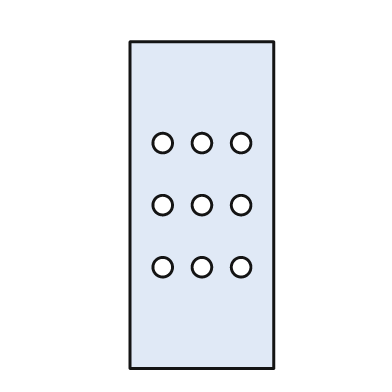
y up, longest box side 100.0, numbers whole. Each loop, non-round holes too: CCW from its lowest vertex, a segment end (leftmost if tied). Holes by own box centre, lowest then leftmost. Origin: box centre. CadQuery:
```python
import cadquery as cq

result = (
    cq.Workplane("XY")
    .moveTo(-22.0, -50.0)
    .lineTo(22.0, -50.0)
    .lineTo(22.0, 50.0)
    .lineTo(-22.0, 50.0)
    .close()
    .moveTo(-12.0, -19.0)
    .circle(3.0)
    .moveTo(0.0, -19.0)
    .circle(3.0)
    .moveTo(12.0, -19.0)
    .circle(3.0)
    .moveTo(-12.0, 0.0)
    .circle(3.0)
    .moveTo(0.0, 0.0)
    .circle(3.0)
    .moveTo(12.0, 0.0)
    .circle(3.0)
    .moveTo(-12.0, 19.0)
    .circle(3.0)
    .moveTo(0.0, 19.0)
    .circle(3.0)
    .moveTo(12.0, 19.0)
    .circle(3.0)
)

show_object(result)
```